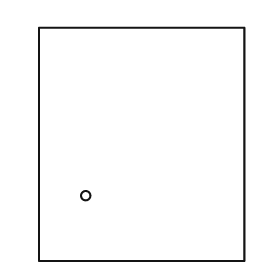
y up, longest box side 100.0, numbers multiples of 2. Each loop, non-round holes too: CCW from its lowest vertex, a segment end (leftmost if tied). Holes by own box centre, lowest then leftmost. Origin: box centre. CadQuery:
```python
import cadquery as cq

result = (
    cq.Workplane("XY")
    .moveTo(-44.0, -50.0)
    .lineTo(44.0, -50.0)
    .lineTo(44.0, 50.0)
    .lineTo(-44.0, 50.0)
    .close()
    .moveTo(-24.0, -22.0)
    .circle(2.0)
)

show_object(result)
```